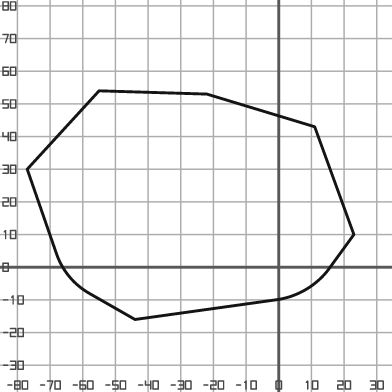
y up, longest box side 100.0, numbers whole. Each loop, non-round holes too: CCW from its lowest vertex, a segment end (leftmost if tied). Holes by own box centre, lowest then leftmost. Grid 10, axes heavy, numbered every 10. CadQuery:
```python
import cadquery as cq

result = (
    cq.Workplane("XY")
    .moveTo(-44.0, -16.0)
    .lineTo(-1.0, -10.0)
    .threePointArc((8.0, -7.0), (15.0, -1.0))
    .lineTo(23.0, 10.0)
    .lineTo(11.0, 43.0)
    .lineTo(-22.0, 53.0)
    .lineTo(-55.0, 54.0)
    .lineTo(-77.0, 30.0)
    .lineTo(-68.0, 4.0)
    .threePointArc((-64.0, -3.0), (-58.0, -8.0))
    .close()
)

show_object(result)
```